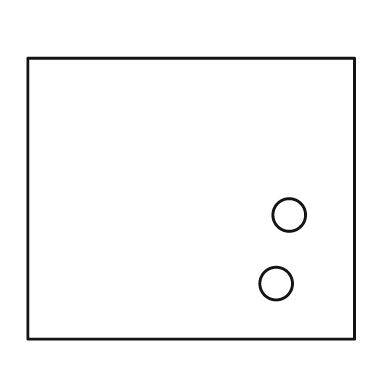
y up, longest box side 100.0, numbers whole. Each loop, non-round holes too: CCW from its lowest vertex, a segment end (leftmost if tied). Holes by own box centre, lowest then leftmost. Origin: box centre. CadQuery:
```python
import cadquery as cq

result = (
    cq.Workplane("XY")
    .moveTo(-50.0, -43.0)
    .lineTo(50.0, -43.0)
    .lineTo(50.0, 43.0)
    .lineTo(-50.0, 43.0)
    .close()
    .moveTo(26.0, -26.0)
    .circle(5.0)
    .moveTo(30.0, -5.0)
    .circle(5.0)
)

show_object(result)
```